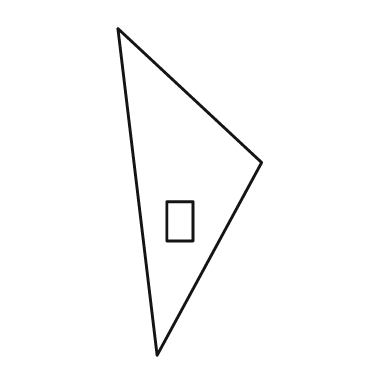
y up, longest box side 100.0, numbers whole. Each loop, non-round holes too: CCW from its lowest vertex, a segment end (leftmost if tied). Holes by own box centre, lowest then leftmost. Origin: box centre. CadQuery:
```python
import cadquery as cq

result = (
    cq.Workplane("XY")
    .moveTo(-10.0, -50.0)
    .lineTo(22.0, 9.0)
    .lineTo(-22.0, 50.0)
    .close()
    .moveTo(-7.0, -15.0)
    .lineTo(1.0, -15.0)
    .lineTo(1.0, -3.0)
    .lineTo(-7.0, -3.0)
    .close()
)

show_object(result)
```